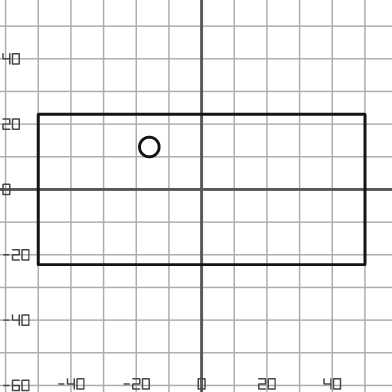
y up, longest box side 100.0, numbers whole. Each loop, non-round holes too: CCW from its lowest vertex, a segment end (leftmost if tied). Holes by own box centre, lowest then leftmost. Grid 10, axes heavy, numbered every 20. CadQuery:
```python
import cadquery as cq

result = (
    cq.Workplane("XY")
    .moveTo(-50.0, -23.0)
    .lineTo(50.0, -23.0)
    .lineTo(50.0, 23.0)
    .lineTo(-50.0, 23.0)
    .close()
    .moveTo(-16.0, 13.0)
    .circle(3.0)
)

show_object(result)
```